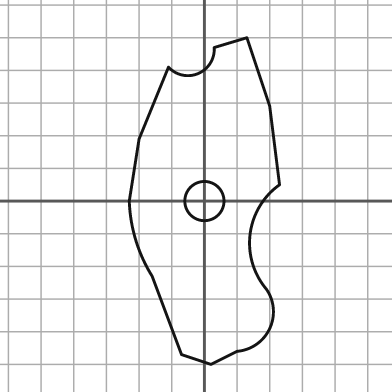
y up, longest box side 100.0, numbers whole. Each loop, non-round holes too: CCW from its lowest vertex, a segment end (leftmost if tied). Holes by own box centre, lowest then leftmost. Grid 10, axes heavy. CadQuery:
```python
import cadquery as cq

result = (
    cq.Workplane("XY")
    .moveTo(2.0, -50.0)
    .lineTo(10.0, -46.0)
    .threePointArc((20.0, -39.0), (19.0, -27.0))
    .threePointArc((14.0, -10.0), (23.0, 5.0))
    .lineTo(20.0, 29.0)
    .lineTo(13.0, 50.0)
    .lineTo(3.0, 47.0)
    .threePointArc((-2.0, 39.0), (-11.0, 41.0))
    .lineTo(-20.0, 19.0)
    .lineTo(-23.0, 0.0)
    .threePointArc((-21.0, -12.0), (-16.0, -23.0))
    .lineTo(-7.0, -47.0)
    .close()
    .moveTo(0.0, 0.0)
    .circle(6.0)
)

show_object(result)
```